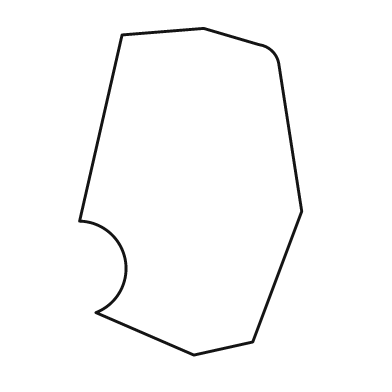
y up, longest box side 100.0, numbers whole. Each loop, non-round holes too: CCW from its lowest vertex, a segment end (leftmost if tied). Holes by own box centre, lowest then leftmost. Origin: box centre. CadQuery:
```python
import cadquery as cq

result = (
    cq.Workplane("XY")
    .moveTo(1.0, -50.0)
    .lineTo(19.0, -46.0)
    .lineTo(34.0, -6.0)
    .lineTo(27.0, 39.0)
    .threePointArc((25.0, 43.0), (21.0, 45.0))
    .lineTo(4.0, 50.0)
    .lineTo(-21.0, 48.0)
    .lineTo(-34.0, -9.0)
    .threePointArc((-20.0, -21.0), (-29.0, -37.0))
    .close()
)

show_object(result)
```